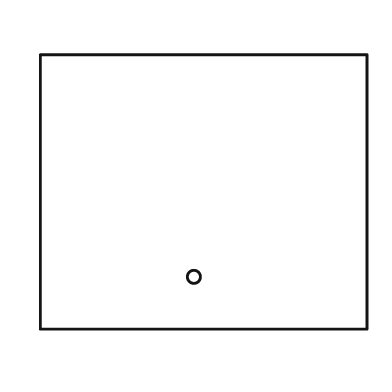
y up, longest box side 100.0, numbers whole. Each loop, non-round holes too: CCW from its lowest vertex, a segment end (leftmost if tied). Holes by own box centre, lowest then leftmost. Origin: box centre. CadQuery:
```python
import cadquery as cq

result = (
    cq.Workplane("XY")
    .moveTo(-50.0, -42.0)
    .lineTo(50.0, -42.0)
    .lineTo(50.0, 42.0)
    .lineTo(-50.0, 42.0)
    .close()
    .moveTo(-3.0, -26.0)
    .circle(2.0)
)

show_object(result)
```